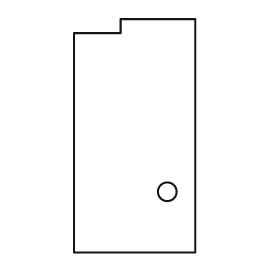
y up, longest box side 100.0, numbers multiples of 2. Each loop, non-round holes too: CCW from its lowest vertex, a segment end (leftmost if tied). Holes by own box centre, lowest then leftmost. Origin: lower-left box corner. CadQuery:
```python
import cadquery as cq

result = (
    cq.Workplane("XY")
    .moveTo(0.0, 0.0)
    .lineTo(52.0, 0.0)
    .lineTo(52.0, 100.0)
    .lineTo(20.0, 100.0)
    .lineTo(20.0, 94.0)
    .lineTo(0.0, 94.0)
    .close()
    .moveTo(40.0, 26.0)
    .circle(4.0)
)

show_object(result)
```